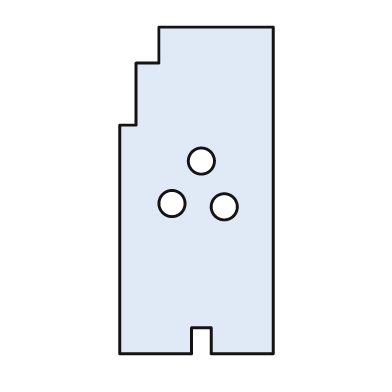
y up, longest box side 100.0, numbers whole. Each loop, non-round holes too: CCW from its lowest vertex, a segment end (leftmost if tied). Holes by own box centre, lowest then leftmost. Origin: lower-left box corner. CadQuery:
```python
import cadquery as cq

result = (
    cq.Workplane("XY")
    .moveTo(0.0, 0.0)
    .lineTo(22.0, 0.0)
    .lineTo(22.0, 8.0)
    .lineTo(28.0, 8.0)
    .lineTo(28.0, 0.0)
    .lineTo(47.0, 0.0)
    .lineTo(47.0, 100.0)
    .lineTo(12.0, 100.0)
    .lineTo(12.0, 89.0)
    .lineTo(5.0, 89.0)
    .lineTo(5.0, 70.0)
    .lineTo(0.0, 70.0)
    .close()
    .moveTo(32.0, 45.0)
    .circle(4.0)
    .moveTo(16.0, 46.0)
    .circle(4.0)
    .moveTo(25.0, 59.0)
    .circle(4.0)
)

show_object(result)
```